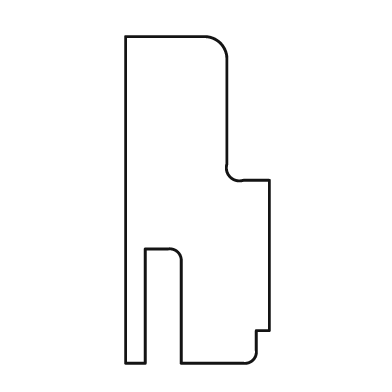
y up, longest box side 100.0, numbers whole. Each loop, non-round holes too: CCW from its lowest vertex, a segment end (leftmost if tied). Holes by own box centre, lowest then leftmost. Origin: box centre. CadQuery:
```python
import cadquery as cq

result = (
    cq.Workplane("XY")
    .moveTo(-22.0, -50.0)
    .lineTo(-16.0, -50.0)
    .lineTo(-16.0, -15.0)
    .lineTo(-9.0, -15.0)
    .threePointArc((-6.0, -16.0), (-5.0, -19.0))
    .lineTo(-5.0, -50.0)
    .lineTo(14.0, -50.0)
    .threePointArc((17.0, -49.0), (18.0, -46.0))
    .lineTo(18.0, -40.0)
    .lineTo(22.0, -40.0)
    .lineTo(22.0, 6.0)
    .lineTo(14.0, 6.0)
    .threePointArc((10.0, 7.0), (9.0, 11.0))
    .lineTo(9.0, 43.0)
    .threePointArc((7.0, 48.0), (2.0, 50.0))
    .lineTo(-22.0, 50.0)
    .close()
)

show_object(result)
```